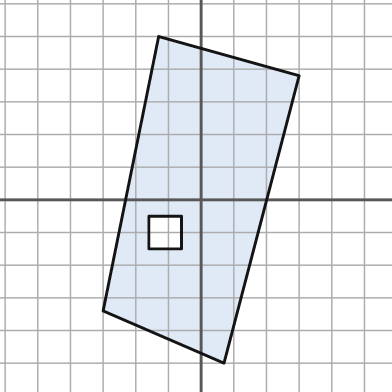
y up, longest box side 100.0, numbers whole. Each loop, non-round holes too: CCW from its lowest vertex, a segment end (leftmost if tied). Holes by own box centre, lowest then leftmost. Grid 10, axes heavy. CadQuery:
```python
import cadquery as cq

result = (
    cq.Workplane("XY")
    .moveTo(7.0, -50.0)
    .lineTo(30.0, 38.0)
    .lineTo(-13.0, 50.0)
    .lineTo(-30.0, -34.0)
    .close()
    .moveTo(-16.0, -15.0)
    .lineTo(-6.0, -15.0)
    .lineTo(-6.0, -5.0)
    .lineTo(-16.0, -5.0)
    .close()
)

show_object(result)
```